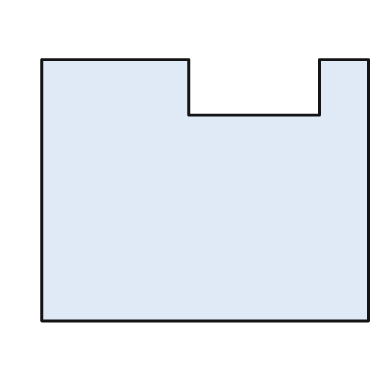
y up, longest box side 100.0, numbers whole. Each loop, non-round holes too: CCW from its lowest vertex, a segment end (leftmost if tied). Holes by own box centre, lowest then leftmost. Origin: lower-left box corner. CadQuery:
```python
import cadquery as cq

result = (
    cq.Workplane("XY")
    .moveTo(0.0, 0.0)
    .lineTo(100.0, 0.0)
    .lineTo(100.0, 80.0)
    .lineTo(85.0, 80.0)
    .lineTo(85.0, 63.0)
    .lineTo(45.0, 63.0)
    .lineTo(45.0, 80.0)
    .lineTo(0.0, 80.0)
    .close()
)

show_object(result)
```